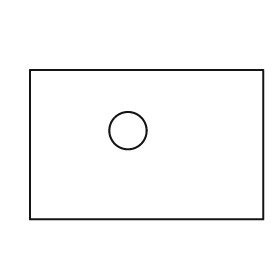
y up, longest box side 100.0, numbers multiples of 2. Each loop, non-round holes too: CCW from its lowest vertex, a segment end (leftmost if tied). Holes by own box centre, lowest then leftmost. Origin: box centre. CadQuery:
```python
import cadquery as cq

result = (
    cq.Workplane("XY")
    .moveTo(-50.0, -32.0)
    .lineTo(50.0, -32.0)
    .lineTo(50.0, 32.0)
    .lineTo(-50.0, 32.0)
    .close()
    .moveTo(-8.0, 6.0)
    .circle(8.0)
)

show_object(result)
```